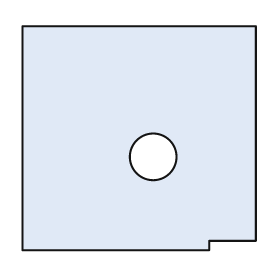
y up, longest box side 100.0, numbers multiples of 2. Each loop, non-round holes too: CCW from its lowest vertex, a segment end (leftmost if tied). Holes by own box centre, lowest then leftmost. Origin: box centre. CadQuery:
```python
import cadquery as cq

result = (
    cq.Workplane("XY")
    .moveTo(-50.0, -48.0)
    .lineTo(30.0, -48.0)
    .lineTo(30.0, -44.0)
    .lineTo(50.0, -44.0)
    .lineTo(50.0, 48.0)
    .lineTo(-50.0, 48.0)
    .close()
    .moveTo(6.0, -8.0)
    .circle(10.0)
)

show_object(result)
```